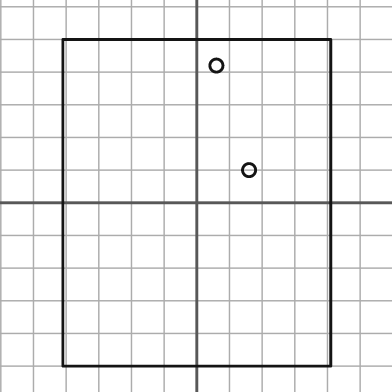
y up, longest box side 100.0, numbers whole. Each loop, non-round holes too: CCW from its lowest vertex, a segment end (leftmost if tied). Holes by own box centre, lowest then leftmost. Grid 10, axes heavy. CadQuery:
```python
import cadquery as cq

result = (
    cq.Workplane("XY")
    .moveTo(-41.0, -50.0)
    .lineTo(41.0, -50.0)
    .lineTo(41.0, 50.0)
    .lineTo(-41.0, 50.0)
    .close()
    .moveTo(16.0, 10.0)
    .circle(2.0)
    .moveTo(6.0, 42.0)
    .circle(2.0)
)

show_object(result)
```